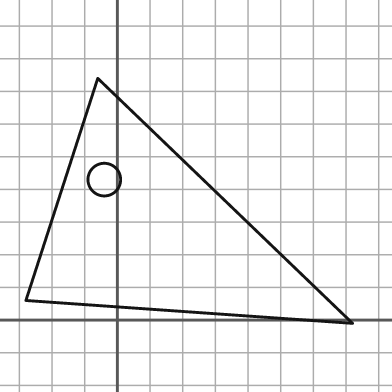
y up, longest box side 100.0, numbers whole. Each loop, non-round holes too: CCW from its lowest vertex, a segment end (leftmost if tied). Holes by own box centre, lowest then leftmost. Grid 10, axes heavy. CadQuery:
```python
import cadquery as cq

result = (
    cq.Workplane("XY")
    .moveTo(72.0, -1.0)
    .lineTo(-6.0, 74.0)
    .lineTo(-28.0, 6.0)
    .close()
    .moveTo(-4.0, 43.0)
    .circle(5.0)
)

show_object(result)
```